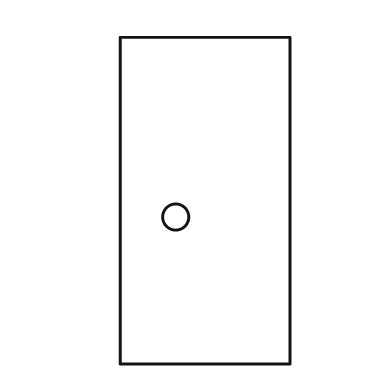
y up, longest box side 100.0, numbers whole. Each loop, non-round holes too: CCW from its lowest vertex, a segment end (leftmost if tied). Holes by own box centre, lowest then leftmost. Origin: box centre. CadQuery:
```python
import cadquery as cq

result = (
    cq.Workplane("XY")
    .moveTo(-26.0, -50.0)
    .lineTo(26.0, -50.0)
    .lineTo(26.0, 50.0)
    .lineTo(-26.0, 50.0)
    .close()
    .moveTo(-9.0, -5.0)
    .circle(4.0)
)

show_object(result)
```